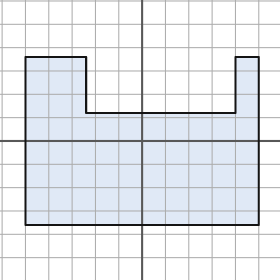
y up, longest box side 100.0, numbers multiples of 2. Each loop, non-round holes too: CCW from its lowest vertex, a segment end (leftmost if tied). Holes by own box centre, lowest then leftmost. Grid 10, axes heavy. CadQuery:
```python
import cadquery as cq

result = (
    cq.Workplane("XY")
    .moveTo(-50.0, -36.0)
    .lineTo(50.0, -36.0)
    .lineTo(50.0, 36.0)
    .lineTo(40.0, 36.0)
    .lineTo(40.0, 12.0)
    .lineTo(-24.0, 12.0)
    .lineTo(-24.0, 36.0)
    .lineTo(-50.0, 36.0)
    .close()
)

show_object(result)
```